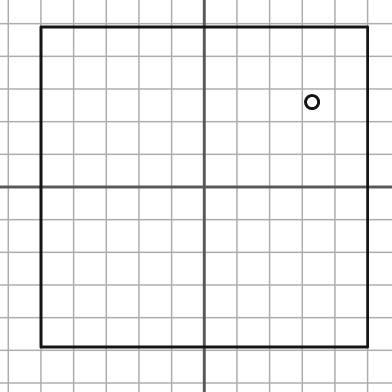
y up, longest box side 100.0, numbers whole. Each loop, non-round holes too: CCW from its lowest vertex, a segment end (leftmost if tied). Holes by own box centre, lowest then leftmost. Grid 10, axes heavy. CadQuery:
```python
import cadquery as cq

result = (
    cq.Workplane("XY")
    .moveTo(-50.0, -49.0)
    .lineTo(50.0, -49.0)
    .lineTo(50.0, 49.0)
    .lineTo(-50.0, 49.0)
    .close()
    .moveTo(33.0, 26.0)
    .circle(2.0)
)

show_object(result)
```